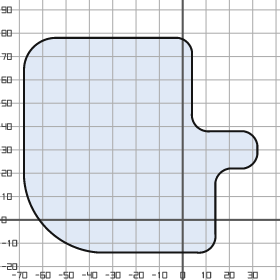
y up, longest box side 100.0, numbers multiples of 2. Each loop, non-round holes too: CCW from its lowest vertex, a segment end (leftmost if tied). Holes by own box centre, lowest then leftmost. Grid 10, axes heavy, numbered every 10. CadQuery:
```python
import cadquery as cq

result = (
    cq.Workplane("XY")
    .moveTo(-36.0, -14.0)
    .lineTo(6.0, -14.0)
    .threePointArc((12.0, -12.0), (14.0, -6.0))
    .lineTo(14.0, 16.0)
    .threePointArc((16.0, 20.0), (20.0, 22.0))
    .lineTo(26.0, 22.0)
    .threePointArc((30.0, 24.0), (32.0, 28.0))
    .lineTo(32.0, 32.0)
    .threePointArc((30.0, 36.0), (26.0, 38.0))
    .lineTo(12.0, 38.0)
    .threePointArc((6.0, 40.0), (4.0, 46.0))
    .lineTo(4.0, 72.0)
    .threePointArc((2.0, 76.0), (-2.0, 78.0))
    .lineTo(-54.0, 78.0)
    .threePointArc((-64.0, 74.0), (-68.0, 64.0))
    .lineTo(-68.0, 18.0)
    .threePointArc((-58.0, -4.0), (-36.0, -14.0))
    .close()
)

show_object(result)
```